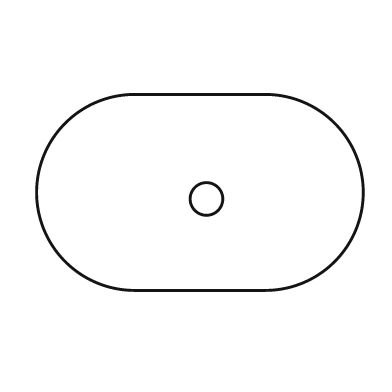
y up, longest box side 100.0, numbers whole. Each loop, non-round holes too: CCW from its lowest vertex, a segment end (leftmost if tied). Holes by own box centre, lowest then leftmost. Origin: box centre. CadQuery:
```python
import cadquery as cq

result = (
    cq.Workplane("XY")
    .moveTo(-20.0, -30.0)
    .lineTo(20.0, -30.0)
    .threePointArc((50.0, 0.0), (20.0, 30.0))
    .lineTo(-20.0, 30.0)
    .threePointArc((-50.0, 0.0), (-20.0, -30.0))
    .close()
    .moveTo(2.0, -2.0)
    .circle(5.0)
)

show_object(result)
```